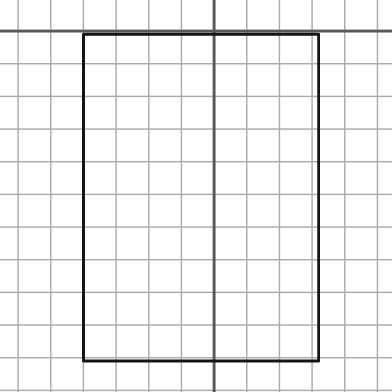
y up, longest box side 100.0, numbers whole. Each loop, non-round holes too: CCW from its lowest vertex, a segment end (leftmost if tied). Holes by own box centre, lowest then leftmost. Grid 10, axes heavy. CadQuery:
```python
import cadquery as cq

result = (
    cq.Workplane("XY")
    .moveTo(-40.0, -101.0)
    .lineTo(32.0, -101.0)
    .lineTo(32.0, -1.0)
    .lineTo(-40.0, -1.0)
    .close()
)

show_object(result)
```